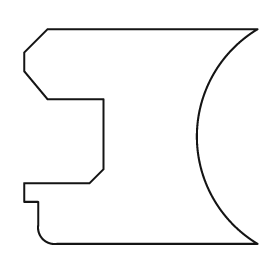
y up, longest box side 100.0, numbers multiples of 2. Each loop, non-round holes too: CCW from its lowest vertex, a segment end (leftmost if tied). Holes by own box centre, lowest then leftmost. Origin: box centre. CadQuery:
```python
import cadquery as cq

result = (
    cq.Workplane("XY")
    .moveTo(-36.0, -46.0)
    .lineTo(50.0, -46.0)
    .threePointArc((24.0, 0.0), (50.0, 46.0))
    .lineTo(-40.0, 46.0)
    .lineTo(-50.0, 36.0)
    .lineTo(-50.0, 28.0)
    .lineTo(-40.0, 16.0)
    .lineTo(-16.0, 16.0)
    .lineTo(-16.0, -14.0)
    .lineTo(-22.0, -20.0)
    .lineTo(-50.0, -20.0)
    .lineTo(-50.0, -28.0)
    .lineTo(-44.0, -28.0)
    .lineTo(-44.0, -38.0)
    .threePointArc((-42.0, -44.0), (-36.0, -46.0))
    .close()
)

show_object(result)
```